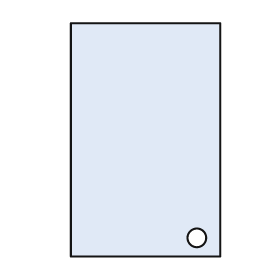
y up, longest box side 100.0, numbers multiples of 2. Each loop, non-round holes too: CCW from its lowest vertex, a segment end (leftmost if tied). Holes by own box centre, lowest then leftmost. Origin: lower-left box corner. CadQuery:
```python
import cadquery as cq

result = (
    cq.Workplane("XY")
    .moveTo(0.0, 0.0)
    .lineTo(64.0, 0.0)
    .lineTo(64.0, 100.0)
    .lineTo(0.0, 100.0)
    .close()
    .moveTo(54.0, 8.0)
    .circle(4.0)
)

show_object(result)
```